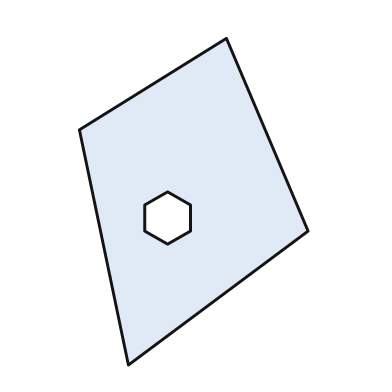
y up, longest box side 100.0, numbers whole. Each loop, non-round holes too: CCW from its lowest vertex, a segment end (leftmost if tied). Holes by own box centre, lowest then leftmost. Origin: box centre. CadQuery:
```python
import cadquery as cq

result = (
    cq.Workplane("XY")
    .moveTo(-20.0, -50.0)
    .lineTo(35.0, -9.0)
    .lineTo(10.0, 50.0)
    .lineTo(-35.0, 22.0)
    .close()
    .moveTo(-8.0, -13.0)
    .lineTo(-1.0, -9.0)
    .lineTo(-1.0, -1.0)
    .lineTo(-8.0, 3.0)
    .lineTo(-15.0, -1.0)
    .lineTo(-15.0, -9.0)
    .close()
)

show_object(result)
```